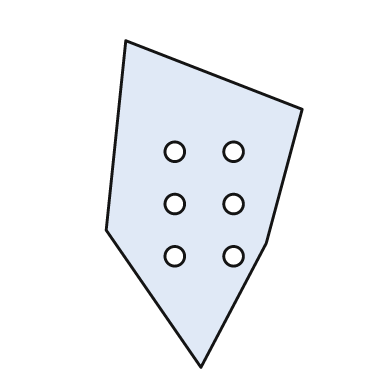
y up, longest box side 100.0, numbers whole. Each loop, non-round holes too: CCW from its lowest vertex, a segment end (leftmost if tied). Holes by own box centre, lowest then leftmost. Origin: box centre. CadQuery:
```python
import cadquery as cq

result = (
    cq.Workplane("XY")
    .moveTo(-1.0, -50.0)
    .lineTo(19.0, -12.0)
    .lineTo(30.0, 29.0)
    .lineTo(-24.0, 50.0)
    .lineTo(-30.0, -8.0)
    .close()
    .moveTo(-9.0, -16.0)
    .circle(3.0)
    .moveTo(9.0, -16.0)
    .circle(3.0)
    .moveTo(-9.0, 0.0)
    .circle(3.0)
    .moveTo(9.0, 0.0)
    .circle(3.0)
    .moveTo(-9.0, 16.0)
    .circle(3.0)
    .moveTo(9.0, 16.0)
    .circle(3.0)
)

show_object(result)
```